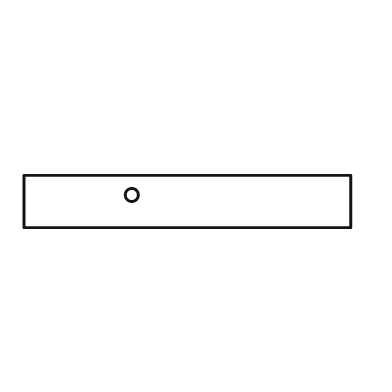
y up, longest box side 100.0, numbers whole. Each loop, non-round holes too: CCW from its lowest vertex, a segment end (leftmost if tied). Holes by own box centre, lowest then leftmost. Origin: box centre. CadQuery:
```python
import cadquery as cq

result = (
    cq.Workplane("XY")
    .moveTo(-50.0, -8.0)
    .lineTo(50.0, -8.0)
    .lineTo(50.0, 8.0)
    .lineTo(-50.0, 8.0)
    .close()
    .moveTo(-17.0, 2.0)
    .circle(2.0)
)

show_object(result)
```